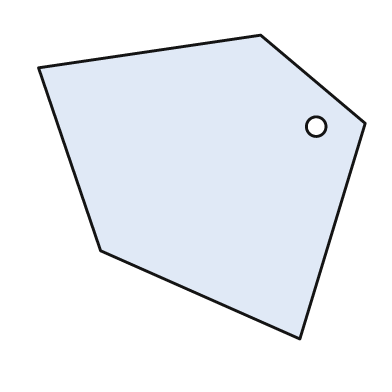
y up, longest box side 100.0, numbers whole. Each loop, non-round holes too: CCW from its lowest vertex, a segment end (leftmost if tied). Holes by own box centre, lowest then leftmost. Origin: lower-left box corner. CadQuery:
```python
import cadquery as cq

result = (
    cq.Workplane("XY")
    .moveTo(80.0, 0.0)
    .lineTo(100.0, 66.0)
    .lineTo(68.0, 93.0)
    .lineTo(0.0, 83.0)
    .lineTo(19.0, 27.0)
    .close()
    .moveTo(85.0, 65.0)
    .circle(3.0)
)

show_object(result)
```